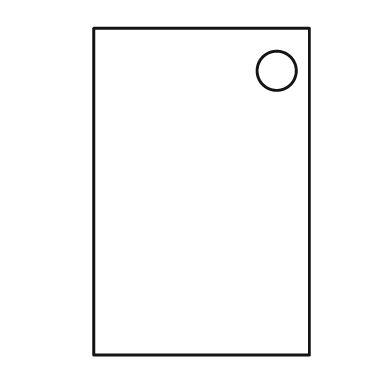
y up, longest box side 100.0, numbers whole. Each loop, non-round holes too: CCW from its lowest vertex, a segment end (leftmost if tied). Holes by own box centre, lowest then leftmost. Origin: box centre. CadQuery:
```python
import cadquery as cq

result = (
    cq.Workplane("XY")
    .moveTo(-33.0, -50.0)
    .lineTo(33.0, -50.0)
    .lineTo(33.0, 50.0)
    .lineTo(-33.0, 50.0)
    .close()
    .moveTo(23.0, 37.0)
    .circle(6.0)
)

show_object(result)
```